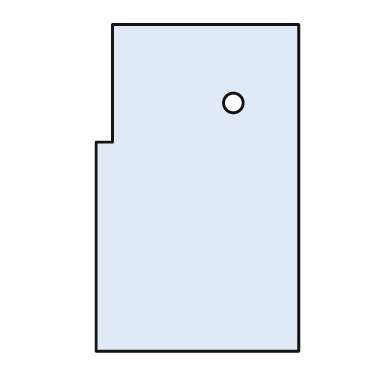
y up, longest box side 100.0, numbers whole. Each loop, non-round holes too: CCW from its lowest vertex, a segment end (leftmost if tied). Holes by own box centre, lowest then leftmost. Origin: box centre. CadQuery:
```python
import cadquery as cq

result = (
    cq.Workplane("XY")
    .moveTo(-31.0, -50.0)
    .lineTo(31.0, -50.0)
    .lineTo(31.0, 50.0)
    .lineTo(-26.0, 50.0)
    .lineTo(-26.0, 14.0)
    .lineTo(-31.0, 14.0)
    .close()
    .moveTo(11.0, 26.0)
    .circle(3.0)
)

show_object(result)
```